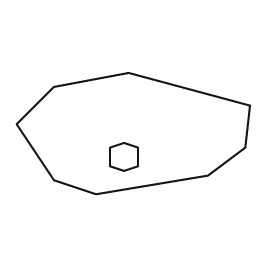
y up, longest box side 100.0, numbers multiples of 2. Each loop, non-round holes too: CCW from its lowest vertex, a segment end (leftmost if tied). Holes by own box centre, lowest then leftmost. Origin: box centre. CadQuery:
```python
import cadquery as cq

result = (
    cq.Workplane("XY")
    .moveTo(-16.0, -26.0)
    .lineTo(32.0, -18.0)
    .lineTo(48.0, -6.0)
    .lineTo(50.0, 12.0)
    .lineTo(-2.0, 26.0)
    .lineTo(-34.0, 20.0)
    .lineTo(-50.0, 4.0)
    .lineTo(-34.0, -20.0)
    .close()
    .moveTo(-4.0, -16.0)
    .lineTo(2.0, -14.0)
    .lineTo(2.0, -6.0)
    .lineTo(-4.0, -4.0)
    .lineTo(-10.0, -6.0)
    .lineTo(-10.0, -14.0)
    .close()
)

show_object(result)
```